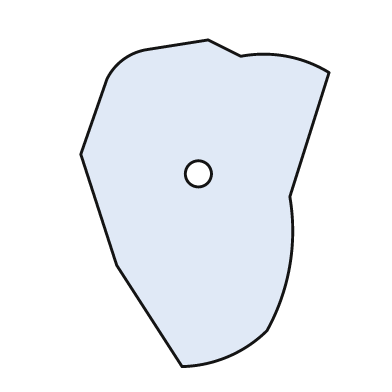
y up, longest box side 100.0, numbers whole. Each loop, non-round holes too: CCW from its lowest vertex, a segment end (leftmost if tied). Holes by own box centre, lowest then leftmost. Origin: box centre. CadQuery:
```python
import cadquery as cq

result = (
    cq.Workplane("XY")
    .moveTo(-7.0, -50.0)
    .threePointArc((7.0, -47.0), (19.0, -39.0))
    .threePointArc((26.0, -19.0), (26.0, 2.0))
    .lineTo(38.0, 40.0)
    .threePointArc((25.0, 45.0), (11.0, 45.0))
    .lineTo(1.0, 50.0)
    .lineTo(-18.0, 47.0)
    .threePointArc((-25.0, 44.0), (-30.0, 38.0))
    .lineTo(-38.0, 15.0)
    .lineTo(-27.0, -19.0)
    .close()
    .moveTo(-2.0, 9.0)
    .circle(4.0)
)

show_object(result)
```